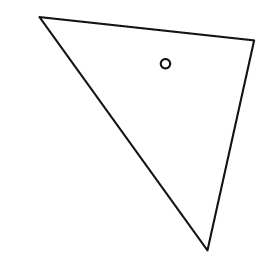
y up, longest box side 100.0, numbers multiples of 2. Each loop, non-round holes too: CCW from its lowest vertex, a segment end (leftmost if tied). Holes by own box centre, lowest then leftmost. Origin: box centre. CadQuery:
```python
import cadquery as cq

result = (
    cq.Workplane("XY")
    .moveTo(26.0, -50.0)
    .lineTo(46.0, 40.0)
    .lineTo(-46.0, 50.0)
    .close()
    .moveTo(8.0, 30.0)
    .circle(2.0)
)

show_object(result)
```